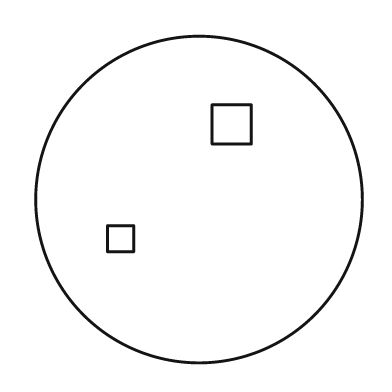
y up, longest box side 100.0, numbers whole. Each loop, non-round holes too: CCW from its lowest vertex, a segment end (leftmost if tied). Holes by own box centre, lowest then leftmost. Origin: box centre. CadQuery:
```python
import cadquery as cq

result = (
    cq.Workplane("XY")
    .moveTo(0.0, 0.0)
    .circle(50.0)
    .moveTo(-28.0, -16.0)
    .lineTo(-20.0, -16.0)
    .lineTo(-20.0, -8.0)
    .lineTo(-28.0, -8.0)
    .close()
    .moveTo(4.0, 17.0)
    .lineTo(16.0, 17.0)
    .lineTo(16.0, 29.0)
    .lineTo(4.0, 29.0)
    .close()
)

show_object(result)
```